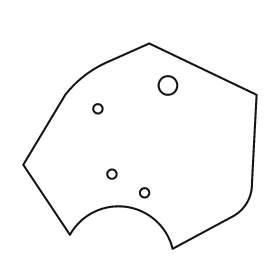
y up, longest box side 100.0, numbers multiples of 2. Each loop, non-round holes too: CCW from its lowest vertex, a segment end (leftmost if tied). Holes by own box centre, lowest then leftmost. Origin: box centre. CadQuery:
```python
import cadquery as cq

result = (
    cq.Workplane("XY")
    .moveTo(14.0, -44.0)
    .lineTo(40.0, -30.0)
    .threePointArc((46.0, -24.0), (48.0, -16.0))
    .lineTo(50.0, 22.0)
    .lineTo(4.0, 44.0)
    .lineTo(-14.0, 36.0)
    .threePointArc((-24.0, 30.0), (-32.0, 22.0))
    .lineTo(-50.0, -8.0)
    .lineTo(-30.0, -38.0)
    .threePointArc((-6.0, -26.0), (14.0, -44.0))
    .close()
    .moveTo(2.0, -20.0)
    .circle(2.0)
    .moveTo(-12.0, -12.0)
    .circle(2.0)
    .moveTo(-18.0, 16.0)
    .circle(2.0)
    .moveTo(12.0, 26.0)
    .circle(4.0)
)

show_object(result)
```